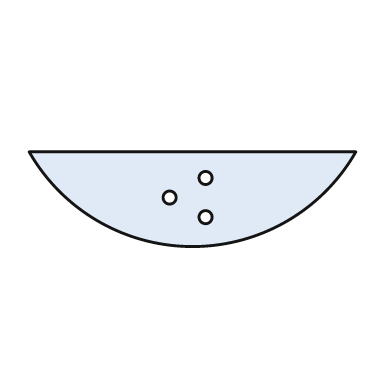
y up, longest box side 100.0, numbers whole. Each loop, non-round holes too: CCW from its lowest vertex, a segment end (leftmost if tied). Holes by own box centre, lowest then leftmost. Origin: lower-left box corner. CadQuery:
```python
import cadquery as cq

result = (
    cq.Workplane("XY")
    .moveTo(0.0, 29.0)
    .threePointArc((50.0, 0.0), (100.0, 29.0))
    .close()
    .moveTo(54.0, 9.0)
    .circle(2.0)
    .moveTo(43.0, 15.0)
    .circle(2.0)
    .moveTo(54.0, 21.0)
    .circle(2.0)
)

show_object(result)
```